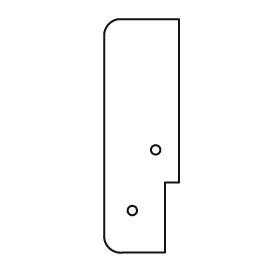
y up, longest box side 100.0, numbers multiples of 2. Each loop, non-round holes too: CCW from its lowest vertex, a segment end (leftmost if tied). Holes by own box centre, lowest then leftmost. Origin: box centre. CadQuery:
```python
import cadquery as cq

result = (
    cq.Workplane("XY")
    .moveTo(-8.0, -50.0)
    .lineTo(10.0, -50.0)
    .lineTo(10.0, -20.0)
    .lineTo(16.0, -20.0)
    .lineTo(16.0, 50.0)
    .lineTo(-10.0, 50.0)
    .threePointArc((-14.0, 48.0), (-16.0, 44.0))
    .lineTo(-16.0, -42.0)
    .threePointArc((-14.0, -48.0), (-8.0, -50.0))
    .close()
    .moveTo(-4.0, -32.0)
    .circle(2.0)
    .moveTo(6.0, -6.0)
    .circle(2.0)
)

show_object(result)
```